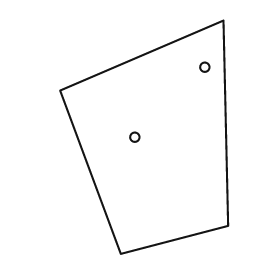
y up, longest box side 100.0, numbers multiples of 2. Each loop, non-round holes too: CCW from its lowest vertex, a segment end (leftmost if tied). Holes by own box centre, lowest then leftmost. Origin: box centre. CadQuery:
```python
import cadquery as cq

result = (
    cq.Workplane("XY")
    .moveTo(-10.0, -50.0)
    .lineTo(36.0, -38.0)
    .lineTo(34.0, 50.0)
    .lineTo(-36.0, 20.0)
    .close()
    .moveTo(-4.0, 0.0)
    .circle(2.0)
    .moveTo(26.0, 30.0)
    .circle(2.0)
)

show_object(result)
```